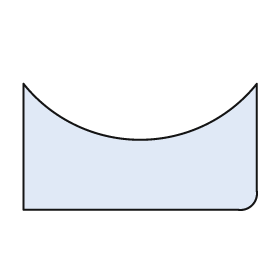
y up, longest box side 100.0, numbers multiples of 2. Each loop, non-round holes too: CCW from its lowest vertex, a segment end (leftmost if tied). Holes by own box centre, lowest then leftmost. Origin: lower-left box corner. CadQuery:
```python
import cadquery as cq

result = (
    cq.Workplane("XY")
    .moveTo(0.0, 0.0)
    .lineTo(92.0, 0.0)
    .threePointArc((98.0, 2.0), (100.0, 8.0))
    .lineTo(100.0, 54.0)
    .threePointArc((50.0, 30.0), (0.0, 54.0))
    .close()
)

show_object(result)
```